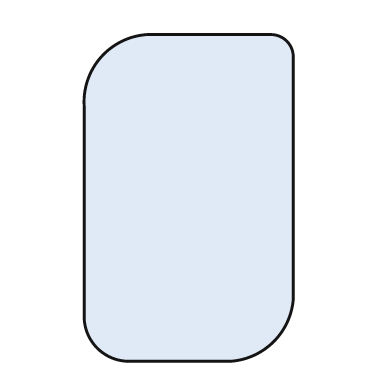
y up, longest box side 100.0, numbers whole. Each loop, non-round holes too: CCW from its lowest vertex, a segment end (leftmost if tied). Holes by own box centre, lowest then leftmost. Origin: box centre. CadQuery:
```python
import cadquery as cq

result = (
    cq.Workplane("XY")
    .moveTo(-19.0, -50.0)
    .lineTo(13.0, -50.0)
    .threePointArc((26.0, -44.0), (32.0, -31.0))
    .lineTo(32.0, 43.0)
    .threePointArc((30.0, 48.0), (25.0, 50.0))
    .lineTo(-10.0, 50.0)
    .threePointArc((-26.0, 44.0), (-32.0, 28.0))
    .lineTo(-32.0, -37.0)
    .threePointArc((-28.0, -46.0), (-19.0, -50.0))
    .close()
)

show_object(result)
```